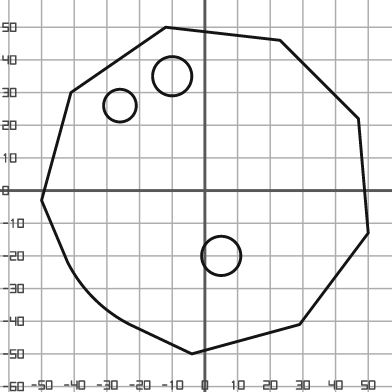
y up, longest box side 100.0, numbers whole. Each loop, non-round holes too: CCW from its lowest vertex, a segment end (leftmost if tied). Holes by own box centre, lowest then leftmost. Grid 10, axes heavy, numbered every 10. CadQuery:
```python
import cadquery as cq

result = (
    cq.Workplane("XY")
    .moveTo(-4.0, -50.0)
    .lineTo(29.0, -41.0)
    .lineTo(50.0, -13.0)
    .lineTo(47.0, 22.0)
    .lineTo(23.0, 46.0)
    .lineTo(-12.0, 50.0)
    .lineTo(-41.0, 30.0)
    .lineTo(-50.0, -3.0)
    .lineTo(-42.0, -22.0)
    .threePointArc((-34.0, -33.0), (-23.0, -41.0))
    .close()
    .moveTo(5.0, -20.0)
    .circle(6.0)
    .moveTo(-26.0, 26.0)
    .circle(5.0)
    .moveTo(-10.0, 35.0)
    .circle(6.0)
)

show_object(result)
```